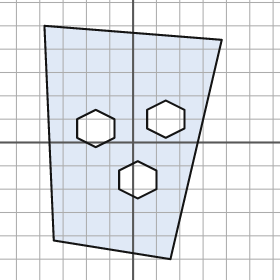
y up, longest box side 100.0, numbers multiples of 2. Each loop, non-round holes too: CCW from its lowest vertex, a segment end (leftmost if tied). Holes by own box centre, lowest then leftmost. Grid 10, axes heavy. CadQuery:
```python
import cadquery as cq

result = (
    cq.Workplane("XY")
    .moveTo(16.0, -50.0)
    .lineTo(38.0, 44.0)
    .lineTo(-38.0, 50.0)
    .lineTo(-34.0, -42.0)
    .close()
    .moveTo(2.0, -24.0)
    .lineTo(10.0, -20.0)
    .lineTo(10.0, -12.0)
    .lineTo(2.0, -8.0)
    .lineTo(-6.0, -12.0)
    .lineTo(-6.0, -20.0)
    .close()
    .moveTo(-16.0, -2.0)
    .lineTo(-8.0, 2.0)
    .lineTo(-8.0, 10.0)
    .lineTo(-16.0, 14.0)
    .lineTo(-24.0, 10.0)
    .lineTo(-24.0, 2.0)
    .close()
    .moveTo(14.0, 2.0)
    .lineTo(22.0, 6.0)
    .lineTo(22.0, 14.0)
    .lineTo(14.0, 18.0)
    .lineTo(6.0, 14.0)
    .lineTo(6.0, 6.0)
    .close()
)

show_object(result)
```